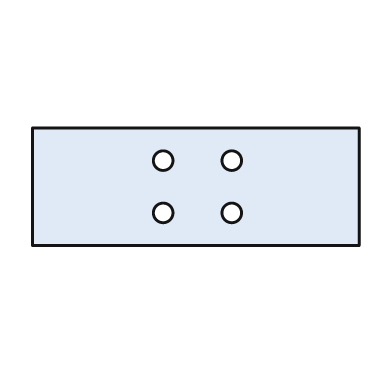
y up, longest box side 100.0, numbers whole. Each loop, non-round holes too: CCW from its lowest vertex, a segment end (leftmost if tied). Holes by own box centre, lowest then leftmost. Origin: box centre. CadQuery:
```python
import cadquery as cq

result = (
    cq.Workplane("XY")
    .moveTo(-50.0, -18.0)
    .lineTo(50.0, -18.0)
    .lineTo(50.0, 18.0)
    .lineTo(-50.0, 18.0)
    .close()
    .moveTo(-10.0, -8.0)
    .circle(3.0)
    .moveTo(11.0, -8.0)
    .circle(3.0)
    .moveTo(-10.0, 8.0)
    .circle(3.0)
    .moveTo(11.0, 8.0)
    .circle(3.0)
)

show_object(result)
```